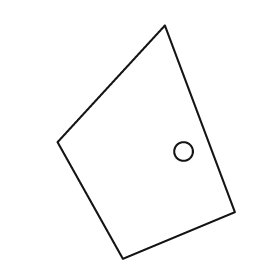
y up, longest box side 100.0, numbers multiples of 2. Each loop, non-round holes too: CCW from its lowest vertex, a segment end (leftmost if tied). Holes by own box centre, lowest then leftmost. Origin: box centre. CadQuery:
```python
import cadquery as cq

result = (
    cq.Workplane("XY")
    .moveTo(-10.0, -50.0)
    .lineTo(38.0, -30.0)
    .lineTo(8.0, 50.0)
    .lineTo(-38.0, 0.0)
    .close()
    .moveTo(16.0, -4.0)
    .circle(4.0)
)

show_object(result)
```